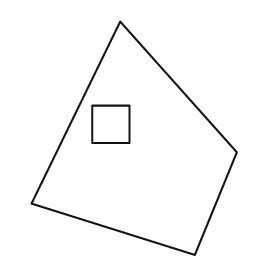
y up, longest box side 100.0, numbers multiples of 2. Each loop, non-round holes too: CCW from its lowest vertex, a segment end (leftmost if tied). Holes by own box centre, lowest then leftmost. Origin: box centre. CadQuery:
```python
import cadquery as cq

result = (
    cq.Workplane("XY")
    .moveTo(26.0, -50.0)
    .lineTo(44.0, -6.0)
    .lineTo(-6.0, 50.0)
    .lineTo(-44.0, -28.0)
    .close()
    .moveTo(-18.0, -2.0)
    .lineTo(-2.0, -2.0)
    .lineTo(-2.0, 14.0)
    .lineTo(-18.0, 14.0)
    .close()
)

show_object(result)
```